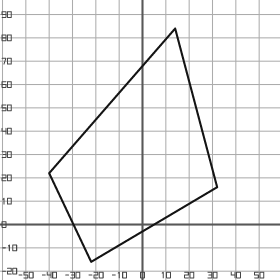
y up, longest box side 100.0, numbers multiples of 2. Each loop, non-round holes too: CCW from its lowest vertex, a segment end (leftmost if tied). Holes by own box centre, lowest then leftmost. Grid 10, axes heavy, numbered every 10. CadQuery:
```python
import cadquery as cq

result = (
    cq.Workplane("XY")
    .moveTo(-22.0, -16.0)
    .lineTo(32.0, 16.0)
    .lineTo(14.0, 84.0)
    .lineTo(-40.0, 22.0)
    .close()
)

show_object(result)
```